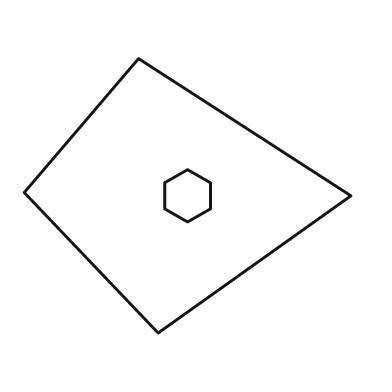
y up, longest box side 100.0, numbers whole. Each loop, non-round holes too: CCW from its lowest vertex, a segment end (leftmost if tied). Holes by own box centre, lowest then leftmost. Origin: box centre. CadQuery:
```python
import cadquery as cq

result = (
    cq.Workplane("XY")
    .moveTo(-9.0, -42.0)
    .lineTo(50.0, 0.0)
    .lineTo(-15.0, 42.0)
    .lineTo(-50.0, 1.0)
    .close()
    .moveTo(0.0, -8.0)
    .lineTo(7.0, -4.0)
    .lineTo(7.0, 4.0)
    .lineTo(0.0, 8.0)
    .lineTo(-7.0, 4.0)
    .lineTo(-7.0, -4.0)
    .close()
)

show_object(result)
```